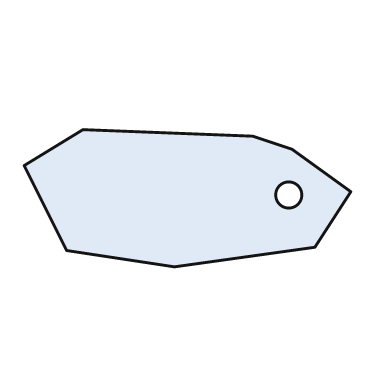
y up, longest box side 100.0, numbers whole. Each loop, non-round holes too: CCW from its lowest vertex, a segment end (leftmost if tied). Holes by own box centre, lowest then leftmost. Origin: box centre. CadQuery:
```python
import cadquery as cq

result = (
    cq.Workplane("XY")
    .moveTo(-4.0, -21.0)
    .lineTo(39.0, -15.0)
    .lineTo(50.0, 2.0)
    .lineTo(32.0, 15.0)
    .lineTo(20.0, 19.0)
    .lineTo(-32.0, 21.0)
    .lineTo(-50.0, 10.0)
    .lineTo(-37.0, -16.0)
    .close()
    .moveTo(31.0, 1.0)
    .circle(4.0)
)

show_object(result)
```